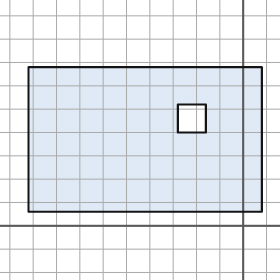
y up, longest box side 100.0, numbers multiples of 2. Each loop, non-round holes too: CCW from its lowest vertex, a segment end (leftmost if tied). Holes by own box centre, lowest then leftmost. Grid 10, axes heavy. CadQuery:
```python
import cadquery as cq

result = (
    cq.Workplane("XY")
    .moveTo(-92.0, 6.0)
    .lineTo(8.0, 6.0)
    .lineTo(8.0, 68.0)
    .lineTo(-92.0, 68.0)
    .close()
    .moveTo(-28.0, 40.0)
    .lineTo(-16.0, 40.0)
    .lineTo(-16.0, 52.0)
    .lineTo(-28.0, 52.0)
    .close()
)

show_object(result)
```